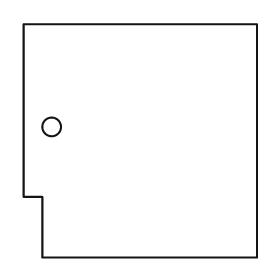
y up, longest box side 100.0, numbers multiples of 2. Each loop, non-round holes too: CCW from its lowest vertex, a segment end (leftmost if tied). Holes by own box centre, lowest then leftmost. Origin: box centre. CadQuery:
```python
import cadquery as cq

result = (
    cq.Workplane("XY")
    .moveTo(-42.0, -50.0)
    .lineTo(50.0, -50.0)
    .lineTo(50.0, 50.0)
    .lineTo(-50.0, 50.0)
    .lineTo(-50.0, -24.0)
    .lineTo(-42.0, -24.0)
    .close()
    .moveTo(-38.0, 6.0)
    .circle(4.0)
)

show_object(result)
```